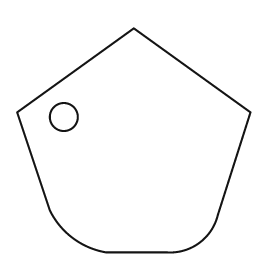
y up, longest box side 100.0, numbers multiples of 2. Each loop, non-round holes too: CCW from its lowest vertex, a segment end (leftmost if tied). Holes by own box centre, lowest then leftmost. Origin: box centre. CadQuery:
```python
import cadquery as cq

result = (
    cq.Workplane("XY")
    .moveTo(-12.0, -48.0)
    .lineTo(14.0, -48.0)
    .threePointArc((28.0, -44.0), (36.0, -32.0))
    .lineTo(50.0, 12.0)
    .lineTo(0.0, 48.0)
    .lineTo(-50.0, 12.0)
    .lineTo(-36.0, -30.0)
    .threePointArc((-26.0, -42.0), (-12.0, -48.0))
    .close()
    .moveTo(-30.0, 10.0)
    .circle(6.0)
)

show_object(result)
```